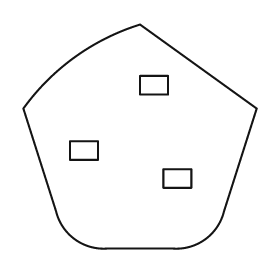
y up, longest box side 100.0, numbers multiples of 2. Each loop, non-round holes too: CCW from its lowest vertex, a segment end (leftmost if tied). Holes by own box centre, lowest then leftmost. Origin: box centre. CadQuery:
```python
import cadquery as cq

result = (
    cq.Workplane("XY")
    .moveTo(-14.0, -48.0)
    .lineTo(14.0, -48.0)
    .threePointArc((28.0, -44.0), (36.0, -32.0))
    .lineTo(50.0, 12.0)
    .lineTo(0.0, 48.0)
    .threePointArc((-28.0, 34.0), (-50.0, 12.0))
    .lineTo(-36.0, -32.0)
    .threePointArc((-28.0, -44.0), (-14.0, -48.0))
    .close()
    .moveTo(10.0, -22.0)
    .lineTo(22.0, -22.0)
    .lineTo(22.0, -14.0)
    .lineTo(10.0, -14.0)
    .close()
    .moveTo(-30.0, -10.0)
    .lineTo(-18.0, -10.0)
    .lineTo(-18.0, -2.0)
    .lineTo(-30.0, -2.0)
    .close()
    .moveTo(0.0, 18.0)
    .lineTo(12.0, 18.0)
    .lineTo(12.0, 26.0)
    .lineTo(0.0, 26.0)
    .close()
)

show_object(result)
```